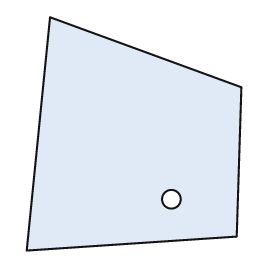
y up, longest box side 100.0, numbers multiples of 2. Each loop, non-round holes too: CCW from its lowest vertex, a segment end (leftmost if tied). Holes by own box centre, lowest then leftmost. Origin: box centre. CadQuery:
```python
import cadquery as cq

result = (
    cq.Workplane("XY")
    .moveTo(-46.0, -50.0)
    .lineTo(44.0, -44.0)
    .lineTo(46.0, 20.0)
    .lineTo(-36.0, 50.0)
    .close()
    .moveTo(16.0, -28.0)
    .circle(4.0)
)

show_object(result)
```